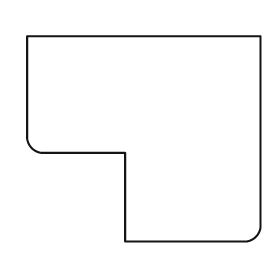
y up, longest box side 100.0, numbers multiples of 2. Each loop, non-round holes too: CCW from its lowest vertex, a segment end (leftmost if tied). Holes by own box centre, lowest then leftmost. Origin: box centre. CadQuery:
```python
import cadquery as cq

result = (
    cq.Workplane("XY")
    .moveTo(-8.0, -44.0)
    .lineTo(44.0, -44.0)
    .threePointArc((48.0, -42.0), (50.0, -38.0))
    .lineTo(50.0, 44.0)
    .lineTo(-50.0, 44.0)
    .lineTo(-50.0, 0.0)
    .threePointArc((-48.0, -4.0), (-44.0, -6.0))
    .lineTo(-8.0, -6.0)
    .close()
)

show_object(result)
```